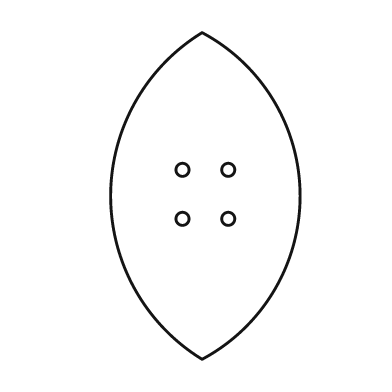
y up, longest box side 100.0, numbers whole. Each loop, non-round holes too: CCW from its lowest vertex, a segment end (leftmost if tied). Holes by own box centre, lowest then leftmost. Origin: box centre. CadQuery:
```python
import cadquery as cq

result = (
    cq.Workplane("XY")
    .moveTo(-1.0, -50.0)
    .threePointArc((29.0, 0.0), (-1.0, 50.0))
    .threePointArc((-29.0, 0.0), (-1.0, -50.0))
    .close()
    .moveTo(-7.0, -7.0)
    .circle(2.0)
    .moveTo(7.0, -7.0)
    .circle(2.0)
    .moveTo(-7.0, 8.0)
    .circle(2.0)
    .moveTo(7.0, 8.0)
    .circle(2.0)
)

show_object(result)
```